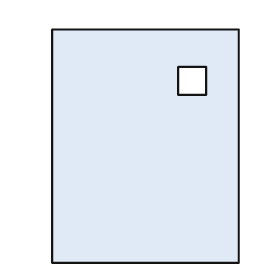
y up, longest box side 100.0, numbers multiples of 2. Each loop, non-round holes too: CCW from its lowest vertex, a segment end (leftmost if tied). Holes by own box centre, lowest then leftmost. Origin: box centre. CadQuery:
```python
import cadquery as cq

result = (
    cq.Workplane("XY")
    .moveTo(-40.0, -50.0)
    .lineTo(40.0, -50.0)
    .lineTo(40.0, 50.0)
    .lineTo(-40.0, 50.0)
    .close()
    .moveTo(14.0, 22.0)
    .lineTo(26.0, 22.0)
    .lineTo(26.0, 34.0)
    .lineTo(14.0, 34.0)
    .close()
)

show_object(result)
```